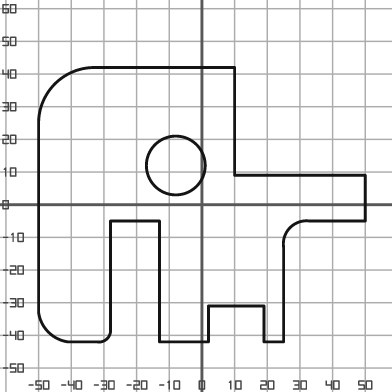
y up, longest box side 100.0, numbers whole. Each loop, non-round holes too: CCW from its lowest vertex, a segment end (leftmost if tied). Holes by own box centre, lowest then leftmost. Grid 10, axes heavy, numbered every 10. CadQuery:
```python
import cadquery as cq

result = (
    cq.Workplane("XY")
    .moveTo(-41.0, -42.0)
    .lineTo(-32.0, -42.0)
    .threePointArc((-29.0, -41.0), (-28.0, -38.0))
    .lineTo(-28.0, -5.0)
    .lineTo(-13.0, -5.0)
    .lineTo(-13.0, -42.0)
    .lineTo(2.0, -42.0)
    .lineTo(2.0, -31.0)
    .lineTo(19.0, -31.0)
    .lineTo(19.0, -42.0)
    .lineTo(25.0, -42.0)
    .lineTo(25.0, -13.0)
    .threePointArc((27.0, -7.0), (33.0, -5.0))
    .lineTo(50.0, -5.0)
    .lineTo(50.0, 9.0)
    .lineTo(10.0, 9.0)
    .lineTo(10.0, 42.0)
    .lineTo(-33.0, 42.0)
    .threePointArc((-45.0, 37.0), (-50.0, 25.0))
    .lineTo(-50.0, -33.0)
    .threePointArc((-47.0, -39.0), (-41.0, -42.0))
    .close()
    .moveTo(-8.0, 12.0)
    .circle(9.0)
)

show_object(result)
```